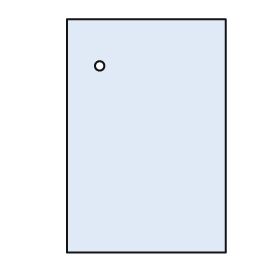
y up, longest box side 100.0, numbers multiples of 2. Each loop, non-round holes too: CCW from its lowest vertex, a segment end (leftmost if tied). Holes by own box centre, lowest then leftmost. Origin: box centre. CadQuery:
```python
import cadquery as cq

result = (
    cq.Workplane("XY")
    .moveTo(-34.0, -50.0)
    .lineTo(34.0, -50.0)
    .lineTo(34.0, 50.0)
    .lineTo(-34.0, 50.0)
    .close()
    .moveTo(-20.0, 30.0)
    .circle(2.0)
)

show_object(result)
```